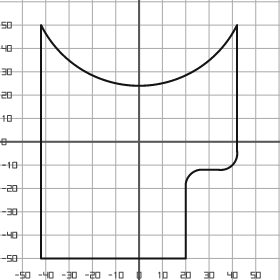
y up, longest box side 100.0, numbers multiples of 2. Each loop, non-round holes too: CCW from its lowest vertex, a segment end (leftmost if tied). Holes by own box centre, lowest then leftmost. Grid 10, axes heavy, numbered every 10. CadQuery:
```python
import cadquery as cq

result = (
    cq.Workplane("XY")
    .moveTo(-42.0, -50.0)
    .lineTo(20.0, -50.0)
    .lineTo(20.0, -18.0)
    .threePointArc((22.0, -14.0), (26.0, -12.0))
    .lineTo(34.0, -12.0)
    .threePointArc((40.0, -10.0), (42.0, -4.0))
    .lineTo(42.0, 50.0)
    .threePointArc((0.0, 24.0), (-42.0, 50.0))
    .close()
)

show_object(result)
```